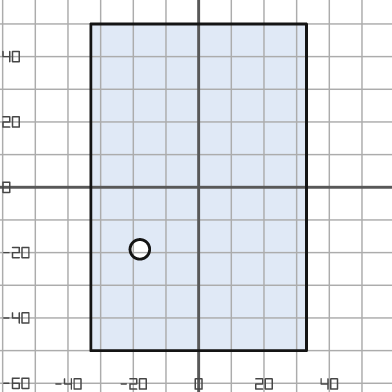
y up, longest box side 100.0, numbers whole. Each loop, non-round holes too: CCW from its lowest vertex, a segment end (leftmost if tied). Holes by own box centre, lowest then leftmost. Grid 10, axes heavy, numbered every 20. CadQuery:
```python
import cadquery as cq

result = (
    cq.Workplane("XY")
    .moveTo(-33.0, -50.0)
    .lineTo(33.0, -50.0)
    .lineTo(33.0, 50.0)
    .lineTo(-33.0, 50.0)
    .close()
    .moveTo(-18.0, -19.0)
    .circle(3.0)
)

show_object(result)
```